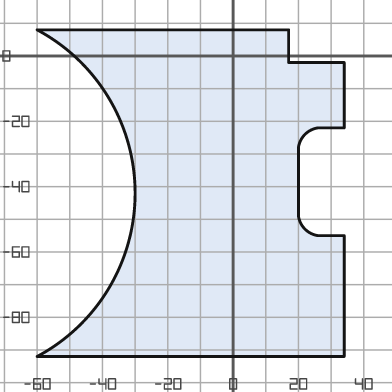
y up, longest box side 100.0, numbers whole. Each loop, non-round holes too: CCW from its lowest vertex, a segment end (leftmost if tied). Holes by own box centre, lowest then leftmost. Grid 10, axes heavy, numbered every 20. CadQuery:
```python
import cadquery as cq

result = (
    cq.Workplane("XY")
    .moveTo(-60.0, -92.0)
    .lineTo(34.0, -92.0)
    .lineTo(34.0, -55.0)
    .lineTo(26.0, -55.0)
    .threePointArc((22.0, -53.0), (20.0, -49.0))
    .lineTo(20.0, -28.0)
    .threePointArc((22.0, -24.0), (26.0, -22.0))
    .lineTo(34.0, -22.0)
    .lineTo(34.0, -2.0)
    .lineTo(17.0, -2.0)
    .lineTo(17.0, 8.0)
    .lineTo(-60.0, 8.0)
    .threePointArc((-30.0, -42.0), (-60.0, -92.0))
    .close()
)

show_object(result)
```